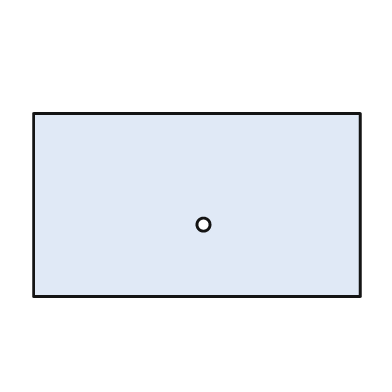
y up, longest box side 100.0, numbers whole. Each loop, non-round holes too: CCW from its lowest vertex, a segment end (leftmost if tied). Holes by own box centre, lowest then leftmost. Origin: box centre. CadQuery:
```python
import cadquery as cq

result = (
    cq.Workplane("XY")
    .moveTo(-50.0, -28.0)
    .lineTo(50.0, -28.0)
    .lineTo(50.0, 28.0)
    .lineTo(-50.0, 28.0)
    .close()
    .moveTo(2.0, -6.0)
    .circle(2.0)
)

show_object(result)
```